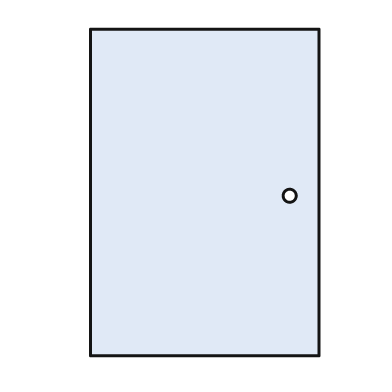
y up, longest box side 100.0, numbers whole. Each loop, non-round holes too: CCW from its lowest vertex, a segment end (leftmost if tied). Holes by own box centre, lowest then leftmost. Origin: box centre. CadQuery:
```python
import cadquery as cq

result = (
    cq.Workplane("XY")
    .moveTo(-35.0, -50.0)
    .lineTo(35.0, -50.0)
    .lineTo(35.0, 50.0)
    .lineTo(-35.0, 50.0)
    .close()
    .moveTo(26.0, -1.0)
    .circle(2.0)
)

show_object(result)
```